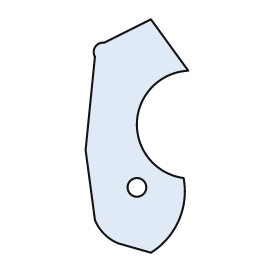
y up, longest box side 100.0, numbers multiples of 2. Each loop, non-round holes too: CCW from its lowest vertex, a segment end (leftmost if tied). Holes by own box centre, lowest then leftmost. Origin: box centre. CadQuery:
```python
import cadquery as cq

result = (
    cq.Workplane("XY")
    .moveTo(6.0, -50.0)
    .threePointArc((18.0, -36.0), (20.0, -18.0))
    .threePointArc((0.0, 6.0), (22.0, 28.0))
    .lineTo(6.0, 50.0)
    .lineTo(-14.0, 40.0)
    .threePointArc((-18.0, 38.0), (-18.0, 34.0))
    .lineTo(-22.0, -6.0)
    .lineTo(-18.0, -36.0)
    .threePointArc((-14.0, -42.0), (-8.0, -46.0))
    .close()
    .moveTo(0.0, -22.0)
    .circle(4.0)
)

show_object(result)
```